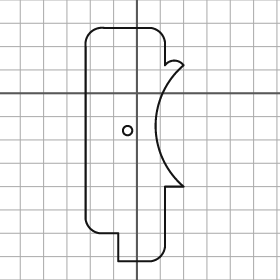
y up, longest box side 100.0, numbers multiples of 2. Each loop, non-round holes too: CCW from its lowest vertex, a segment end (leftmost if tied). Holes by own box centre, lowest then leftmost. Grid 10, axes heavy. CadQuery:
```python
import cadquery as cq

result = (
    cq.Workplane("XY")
    .moveTo(-8.0, -72.0)
    .lineTo(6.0, -72.0)
    .threePointArc((10.0, -70.0), (12.0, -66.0))
    .lineTo(12.0, -40.0)
    .lineTo(20.0, -40.0)
    .threePointArc((8.0, -14.0), (20.0, 12.0))
    .threePointArc((16.0, 14.0), (12.0, 12.0))
    .lineTo(12.0, 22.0)
    .threePointArc((10.0, 26.0), (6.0, 28.0))
    .lineTo(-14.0, 28.0)
    .threePointArc((-20.0, 26.0), (-22.0, 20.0))
    .lineTo(-22.0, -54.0)
    .threePointArc((-20.0, -58.0), (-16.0, -60.0))
    .lineTo(-8.0, -60.0)
    .close()
    .moveTo(-4.0, -16.0)
    .circle(2.0)
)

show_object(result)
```